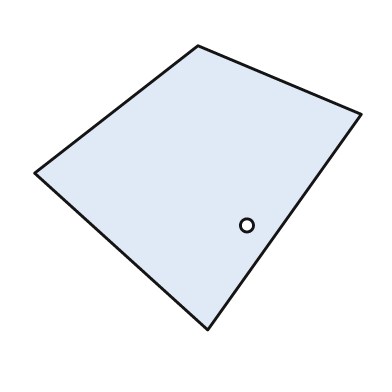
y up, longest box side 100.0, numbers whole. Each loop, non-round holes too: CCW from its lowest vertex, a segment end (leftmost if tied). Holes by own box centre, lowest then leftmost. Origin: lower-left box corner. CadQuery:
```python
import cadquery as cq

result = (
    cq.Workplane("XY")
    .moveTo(53.0, 0.0)
    .lineTo(100.0, 66.0)
    .lineTo(50.0, 87.0)
    .lineTo(0.0, 48.0)
    .close()
    .moveTo(65.0, 32.0)
    .circle(2.0)
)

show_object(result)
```